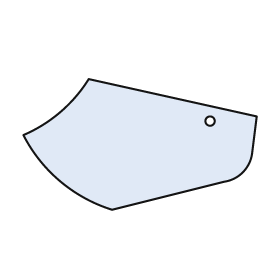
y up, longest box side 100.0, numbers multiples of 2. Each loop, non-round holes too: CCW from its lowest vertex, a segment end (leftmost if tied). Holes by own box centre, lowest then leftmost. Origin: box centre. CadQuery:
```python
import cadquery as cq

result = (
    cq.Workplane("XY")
    .moveTo(-12.0, -28.0)
    .lineTo(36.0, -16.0)
    .threePointArc((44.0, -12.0), (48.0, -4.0))
    .lineTo(50.0, 12.0)
    .lineTo(-22.0, 28.0)
    .threePointArc((-34.0, 14.0), (-50.0, 4.0))
    .threePointArc((-34.0, -16.0), (-12.0, -28.0))
    .close()
    .moveTo(30.0, 10.0)
    .circle(2.0)
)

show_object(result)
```